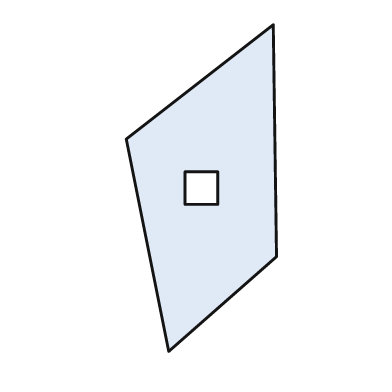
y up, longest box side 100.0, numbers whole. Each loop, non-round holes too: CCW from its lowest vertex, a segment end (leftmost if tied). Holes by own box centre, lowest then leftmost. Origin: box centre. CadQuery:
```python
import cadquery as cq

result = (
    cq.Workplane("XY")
    .moveTo(-10.0, -50.0)
    .lineTo(23.0, -21.0)
    .lineTo(22.0, 50.0)
    .lineTo(-23.0, 15.0)
    .close()
    .moveTo(-5.0, -5.0)
    .lineTo(5.0, -5.0)
    .lineTo(5.0, 5.0)
    .lineTo(-5.0, 5.0)
    .close()
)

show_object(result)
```